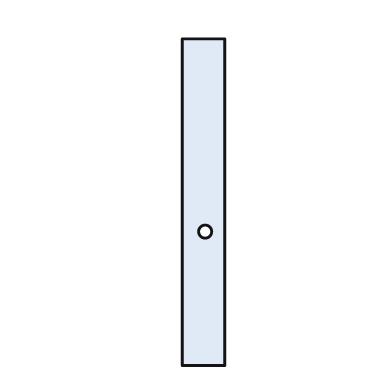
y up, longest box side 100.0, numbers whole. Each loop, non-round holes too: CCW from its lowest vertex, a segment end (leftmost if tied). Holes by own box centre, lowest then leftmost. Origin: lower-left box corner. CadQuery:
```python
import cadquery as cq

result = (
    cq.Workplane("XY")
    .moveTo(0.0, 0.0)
    .lineTo(13.0, 0.0)
    .lineTo(13.0, 100.0)
    .lineTo(0.0, 100.0)
    .close()
    .moveTo(7.0, 41.0)
    .circle(2.0)
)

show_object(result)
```